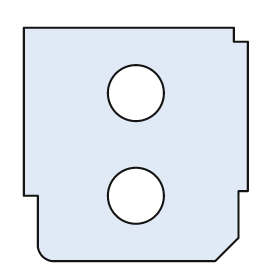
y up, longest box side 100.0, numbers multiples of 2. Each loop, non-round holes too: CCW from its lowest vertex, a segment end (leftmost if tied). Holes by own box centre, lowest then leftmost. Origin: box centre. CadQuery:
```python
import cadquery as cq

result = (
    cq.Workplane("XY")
    .moveTo(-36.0, -50.0)
    .lineTo(34.0, -50.0)
    .lineTo(44.0, -40.0)
    .lineTo(44.0, -20.0)
    .lineTo(48.0, -20.0)
    .lineTo(48.0, 44.0)
    .lineTo(42.0, 44.0)
    .lineTo(42.0, 50.0)
    .lineTo(-48.0, 50.0)
    .lineTo(-48.0, -22.0)
    .lineTo(-42.0, -22.0)
    .lineTo(-42.0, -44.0)
    .threePointArc((-40.0, -48.0), (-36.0, -50.0))
    .close()
    .moveTo(0.0, -22.0)
    .circle(12.0)
    .moveTo(0.0, 22.0)
    .circle(12.0)
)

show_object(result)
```